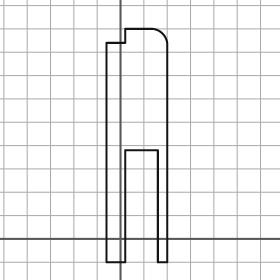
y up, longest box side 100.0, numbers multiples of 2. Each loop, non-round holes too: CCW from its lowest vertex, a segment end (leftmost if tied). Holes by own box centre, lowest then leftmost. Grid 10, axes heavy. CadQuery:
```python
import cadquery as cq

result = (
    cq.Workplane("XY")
    .moveTo(-6.0, -10.0)
    .lineTo(2.0, -10.0)
    .lineTo(2.0, 38.0)
    .lineTo(16.0, 38.0)
    .lineTo(16.0, -10.0)
    .lineTo(20.0, -10.0)
    .lineTo(20.0, 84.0)
    .threePointArc((18.0, 88.0), (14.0, 90.0))
    .lineTo(2.0, 90.0)
    .lineTo(2.0, 84.0)
    .lineTo(-6.0, 84.0)
    .close()
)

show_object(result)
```